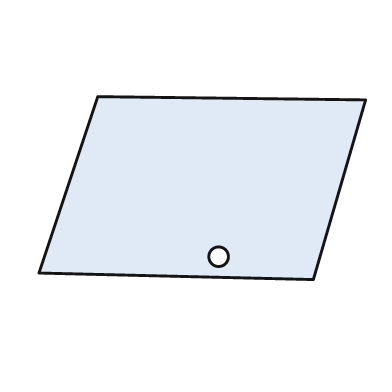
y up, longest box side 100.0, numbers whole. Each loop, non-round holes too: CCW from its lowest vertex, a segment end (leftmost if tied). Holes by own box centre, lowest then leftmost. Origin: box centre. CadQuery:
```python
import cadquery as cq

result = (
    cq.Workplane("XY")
    .moveTo(34.0, -28.0)
    .lineTo(50.0, 27.0)
    .lineTo(-32.0, 28.0)
    .lineTo(-50.0, -26.0)
    .close()
    .moveTo(5.0, -21.0)
    .circle(3.0)
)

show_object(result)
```